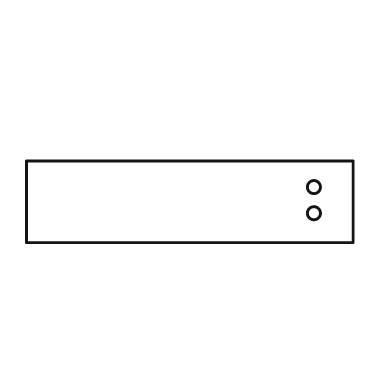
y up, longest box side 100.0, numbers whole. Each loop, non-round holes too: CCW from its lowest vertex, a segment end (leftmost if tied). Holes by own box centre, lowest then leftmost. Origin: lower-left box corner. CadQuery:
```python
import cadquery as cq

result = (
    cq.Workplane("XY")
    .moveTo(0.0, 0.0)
    .lineTo(100.0, 0.0)
    .lineTo(100.0, 25.0)
    .lineTo(0.0, 25.0)
    .close()
    .moveTo(88.0, 9.0)
    .circle(2.0)
    .moveTo(88.0, 17.0)
    .circle(2.0)
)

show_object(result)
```